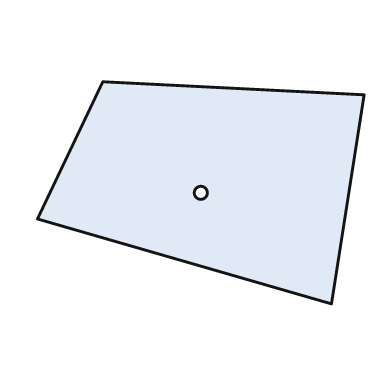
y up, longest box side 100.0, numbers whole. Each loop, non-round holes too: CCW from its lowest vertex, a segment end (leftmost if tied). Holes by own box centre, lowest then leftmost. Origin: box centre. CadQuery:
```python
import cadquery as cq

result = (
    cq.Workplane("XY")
    .moveTo(40.0, -34.0)
    .lineTo(50.0, 30.0)
    .lineTo(-30.0, 34.0)
    .lineTo(-50.0, -8.0)
    .close()
    .moveTo(0.0, 0.0)
    .circle(2.0)
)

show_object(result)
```